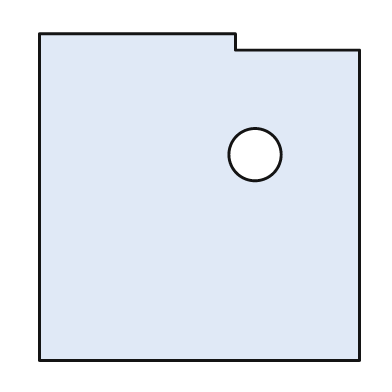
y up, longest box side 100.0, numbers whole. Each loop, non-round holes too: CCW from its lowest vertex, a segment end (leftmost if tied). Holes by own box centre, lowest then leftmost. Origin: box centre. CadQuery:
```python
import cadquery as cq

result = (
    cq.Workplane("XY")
    .moveTo(-49.0, -50.0)
    .lineTo(49.0, -50.0)
    .lineTo(49.0, 45.0)
    .lineTo(11.0, 45.0)
    .lineTo(11.0, 50.0)
    .lineTo(-49.0, 50.0)
    .close()
    .moveTo(17.0, 13.0)
    .circle(8.0)
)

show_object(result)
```